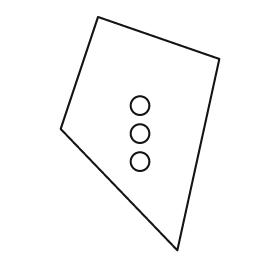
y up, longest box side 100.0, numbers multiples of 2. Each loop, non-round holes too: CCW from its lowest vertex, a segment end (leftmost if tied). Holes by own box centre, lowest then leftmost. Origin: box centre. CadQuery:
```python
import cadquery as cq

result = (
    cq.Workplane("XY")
    .moveTo(16.0, -50.0)
    .lineTo(34.0, 32.0)
    .lineTo(-18.0, 50.0)
    .lineTo(-34.0, 2.0)
    .close()
    .moveTo(0.0, -12.0)
    .circle(4.0)
    .moveTo(0.0, 0.0)
    .circle(4.0)
    .moveTo(0.0, 12.0)
    .circle(4.0)
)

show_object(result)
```